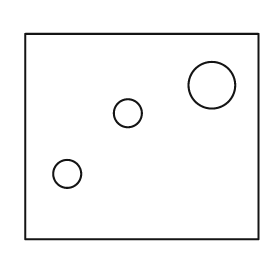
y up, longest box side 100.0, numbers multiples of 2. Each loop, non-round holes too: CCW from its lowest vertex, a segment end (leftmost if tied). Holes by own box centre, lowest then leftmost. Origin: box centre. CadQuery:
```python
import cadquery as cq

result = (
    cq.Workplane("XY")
    .moveTo(-50.0, -44.0)
    .lineTo(50.0, -44.0)
    .lineTo(50.0, 44.0)
    .lineTo(-50.0, 44.0)
    .close()
    .moveTo(-32.0, -16.0)
    .circle(6.0)
    .moveTo(-6.0, 10.0)
    .circle(6.0)
    .moveTo(30.0, 22.0)
    .circle(10.0)
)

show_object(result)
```